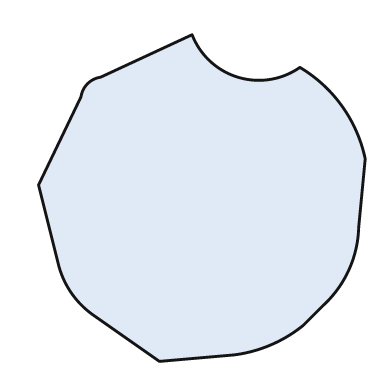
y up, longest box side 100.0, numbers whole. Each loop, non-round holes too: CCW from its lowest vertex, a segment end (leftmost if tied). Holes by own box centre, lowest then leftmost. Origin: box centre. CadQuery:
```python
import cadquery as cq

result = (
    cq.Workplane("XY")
    .moveTo(-13.0, -50.0)
    .lineTo(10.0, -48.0)
    .threePointArc((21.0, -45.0), (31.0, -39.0))
    .lineTo(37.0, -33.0)
    .threePointArc((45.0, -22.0), (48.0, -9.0))
    .lineTo(50.0, 12.0)
    .threePointArc((43.0, 28.0), (30.0, 40.0))
    .threePointArc((11.0, 37.0), (-3.0, 50.0))
    .lineTo(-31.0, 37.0)
    .threePointArc((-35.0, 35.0), (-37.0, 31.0))
    .lineTo(-50.0, 4.0)
    .lineTo(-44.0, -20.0)
    .threePointArc((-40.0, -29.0), (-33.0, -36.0))
    .close()
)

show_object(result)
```